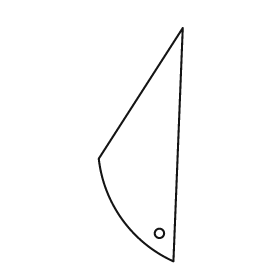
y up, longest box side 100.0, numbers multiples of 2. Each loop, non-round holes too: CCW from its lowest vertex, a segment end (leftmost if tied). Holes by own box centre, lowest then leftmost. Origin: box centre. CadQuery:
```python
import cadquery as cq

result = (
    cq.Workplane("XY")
    .moveTo(14.0, -50.0)
    .lineTo(18.0, 50.0)
    .lineTo(-18.0, -6.0)
    .threePointArc((-8.0, -32.0), (14.0, -50.0))
    .close()
    .moveTo(8.0, -38.0)
    .circle(2.0)
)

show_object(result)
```